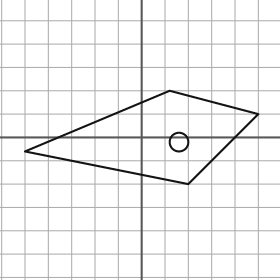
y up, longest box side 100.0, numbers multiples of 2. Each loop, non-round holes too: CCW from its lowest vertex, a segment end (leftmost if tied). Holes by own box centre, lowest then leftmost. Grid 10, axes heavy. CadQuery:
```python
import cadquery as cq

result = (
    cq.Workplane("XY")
    .moveTo(20.0, -20.0)
    .lineTo(50.0, 10.0)
    .lineTo(12.0, 20.0)
    .lineTo(-50.0, -6.0)
    .close()
    .moveTo(16.0, -2.0)
    .circle(4.0)
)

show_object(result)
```